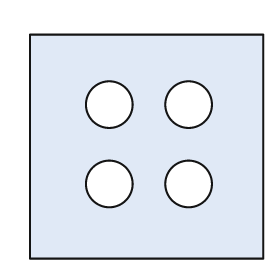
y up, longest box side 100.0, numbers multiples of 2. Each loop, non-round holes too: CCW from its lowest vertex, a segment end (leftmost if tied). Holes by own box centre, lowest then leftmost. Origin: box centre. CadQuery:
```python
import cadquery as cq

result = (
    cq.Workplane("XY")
    .moveTo(-50.0, -48.0)
    .lineTo(50.0, -48.0)
    .lineTo(50.0, 48.0)
    .lineTo(-50.0, 48.0)
    .close()
    .moveTo(-16.0, -16.0)
    .circle(10.0)
    .moveTo(18.0, -16.0)
    .circle(10.0)
    .moveTo(-16.0, 18.0)
    .circle(10.0)
    .moveTo(18.0, 18.0)
    .circle(10.0)
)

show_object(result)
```